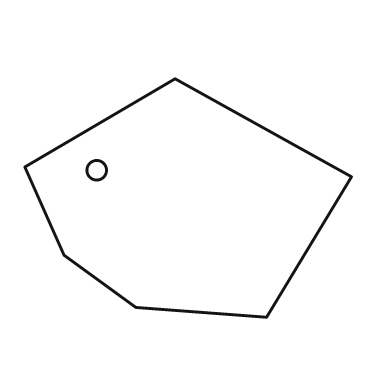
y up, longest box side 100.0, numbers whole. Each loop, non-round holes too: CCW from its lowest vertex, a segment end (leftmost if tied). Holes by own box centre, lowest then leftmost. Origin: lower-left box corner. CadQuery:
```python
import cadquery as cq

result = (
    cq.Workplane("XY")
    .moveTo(74.0, 0.0)
    .lineTo(100.0, 43.0)
    .lineTo(46.0, 73.0)
    .lineTo(0.0, 46.0)
    .lineTo(12.0, 19.0)
    .lineTo(34.0, 3.0)
    .close()
    .moveTo(22.0, 45.0)
    .circle(3.0)
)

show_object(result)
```